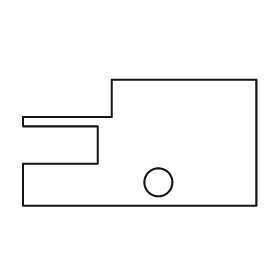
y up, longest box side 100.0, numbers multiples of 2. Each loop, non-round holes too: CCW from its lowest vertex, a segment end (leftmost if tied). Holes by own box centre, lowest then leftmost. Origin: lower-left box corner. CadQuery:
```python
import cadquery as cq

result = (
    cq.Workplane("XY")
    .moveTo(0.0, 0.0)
    .lineTo(100.0, 0.0)
    .lineTo(100.0, 54.0)
    .lineTo(38.0, 54.0)
    .lineTo(38.0, 38.0)
    .lineTo(0.0, 38.0)
    .lineTo(0.0, 34.0)
    .lineTo(32.0, 34.0)
    .lineTo(32.0, 18.0)
    .lineTo(0.0, 18.0)
    .close()
    .moveTo(58.0, 10.0)
    .circle(6.0)
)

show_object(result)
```